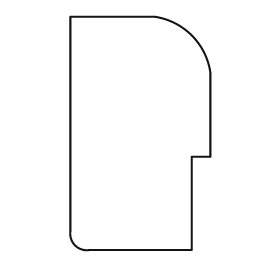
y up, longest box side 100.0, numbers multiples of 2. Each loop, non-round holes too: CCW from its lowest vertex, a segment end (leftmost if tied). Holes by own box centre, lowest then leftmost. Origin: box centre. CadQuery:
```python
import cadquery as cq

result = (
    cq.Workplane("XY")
    .moveTo(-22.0, -50.0)
    .lineTo(22.0, -50.0)
    .lineTo(22.0, -10.0)
    .lineTo(30.0, -10.0)
    .lineTo(30.0, 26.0)
    .threePointArc((22.0, 42.0), (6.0, 50.0))
    .lineTo(-30.0, 50.0)
    .lineTo(-30.0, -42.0)
    .threePointArc((-28.0, -48.0), (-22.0, -50.0))
    .close()
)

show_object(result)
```